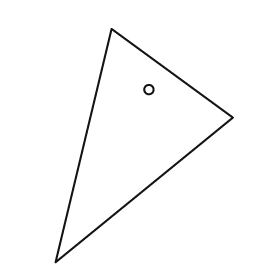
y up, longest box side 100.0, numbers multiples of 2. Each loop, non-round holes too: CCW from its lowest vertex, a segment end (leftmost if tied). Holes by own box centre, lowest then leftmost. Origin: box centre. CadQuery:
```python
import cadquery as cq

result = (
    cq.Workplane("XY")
    .moveTo(-38.0, -50.0)
    .lineTo(38.0, 12.0)
    .lineTo(-14.0, 50.0)
    .close()
    .moveTo(2.0, 24.0)
    .circle(2.0)
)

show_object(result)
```